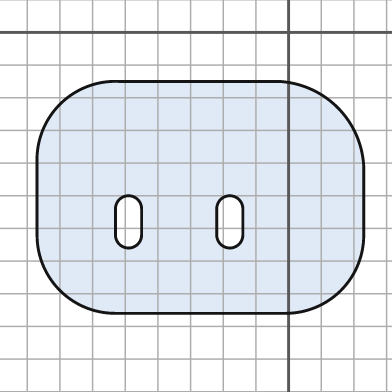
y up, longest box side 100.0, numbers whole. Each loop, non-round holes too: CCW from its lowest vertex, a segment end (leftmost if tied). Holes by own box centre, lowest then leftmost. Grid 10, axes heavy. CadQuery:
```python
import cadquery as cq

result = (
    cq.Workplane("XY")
    .moveTo(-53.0, -86.0)
    .lineTo(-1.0, -86.0)
    .threePointArc((16.0, -79.0), (23.0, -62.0))
    .lineTo(23.0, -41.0)
    .threePointArc((15.0, -23.0), (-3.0, -15.0))
    .lineTo(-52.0, -15.0)
    .threePointArc((-70.0, -22.0), (-77.0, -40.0))
    .lineTo(-77.0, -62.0)
    .threePointArc((-70.0, -79.0), (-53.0, -86.0))
    .close()
    .moveTo(-53.0, -62.0)
    .threePointArc((-49.0, -66.0), (-45.0, -62.0))
    .lineTo(-45.0, -54.0)
    .threePointArc((-49.0, -50.0), (-53.0, -54.0))
    .close()
    .moveTo(-22.0, -62.0)
    .threePointArc((-18.0, -66.0), (-14.0, -62.0))
    .lineTo(-14.0, -54.0)
    .threePointArc((-18.0, -50.0), (-22.0, -54.0))
    .close()
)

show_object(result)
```